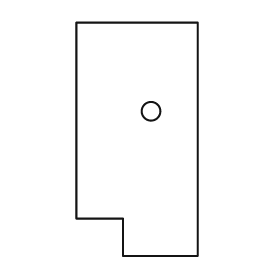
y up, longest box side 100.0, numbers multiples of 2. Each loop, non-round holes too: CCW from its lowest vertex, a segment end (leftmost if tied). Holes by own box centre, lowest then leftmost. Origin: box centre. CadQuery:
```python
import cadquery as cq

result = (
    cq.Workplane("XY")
    .moveTo(-6.0, -50.0)
    .lineTo(26.0, -50.0)
    .lineTo(26.0, 50.0)
    .lineTo(-26.0, 50.0)
    .lineTo(-26.0, -34.0)
    .lineTo(-6.0, -34.0)
    .close()
    .moveTo(6.0, 12.0)
    .circle(4.0)
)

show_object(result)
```